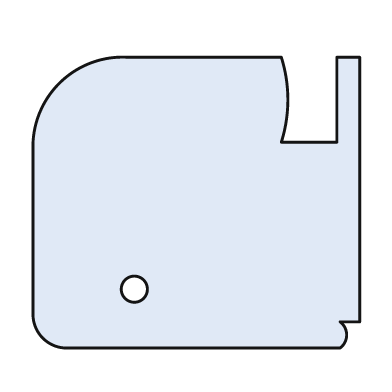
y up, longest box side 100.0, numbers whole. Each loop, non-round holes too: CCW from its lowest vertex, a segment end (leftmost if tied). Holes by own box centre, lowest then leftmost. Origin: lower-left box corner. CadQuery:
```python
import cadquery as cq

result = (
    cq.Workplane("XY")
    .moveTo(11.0, 0.0)
    .lineTo(94.0, 0.0)
    .threePointArc((96.0, 4.0), (94.0, 8.0))
    .lineTo(100.0, 8.0)
    .lineTo(100.0, 89.0)
    .lineTo(93.0, 89.0)
    .lineTo(93.0, 63.0)
    .lineTo(76.0, 63.0)
    .threePointArc((78.0, 76.0), (76.0, 89.0))
    .lineTo(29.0, 89.0)
    .threePointArc((8.0, 81.0), (0.0, 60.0))
    .lineTo(0.0, 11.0)
    .threePointArc((3.0, 3.0), (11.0, 0.0))
    .close()
    .moveTo(31.0, 18.0)
    .circle(4.0)
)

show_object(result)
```